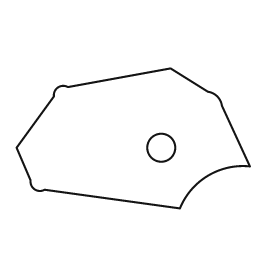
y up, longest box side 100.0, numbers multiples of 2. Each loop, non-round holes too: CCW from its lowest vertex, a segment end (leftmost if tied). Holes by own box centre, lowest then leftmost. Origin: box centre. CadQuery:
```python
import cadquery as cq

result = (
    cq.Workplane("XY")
    .moveTo(20.0, -30.0)
    .threePointArc((32.0, -16.0), (50.0, -12.0))
    .lineTo(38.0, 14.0)
    .threePointArc((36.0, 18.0), (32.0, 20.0))
    .lineTo(16.0, 30.0)
    .lineTo(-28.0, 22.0)
    .threePointArc((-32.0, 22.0), (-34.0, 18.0))
    .lineTo(-50.0, -4.0)
    .lineTo(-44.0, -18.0)
    .threePointArc((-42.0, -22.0), (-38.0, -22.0))
    .close()
    .moveTo(12.0, -4.0)
    .circle(6.0)
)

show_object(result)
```